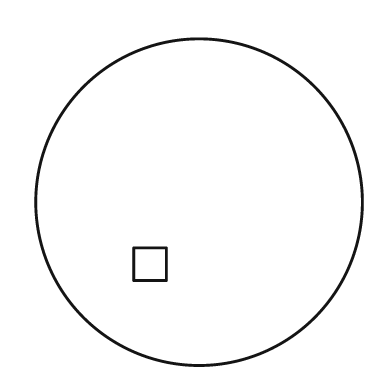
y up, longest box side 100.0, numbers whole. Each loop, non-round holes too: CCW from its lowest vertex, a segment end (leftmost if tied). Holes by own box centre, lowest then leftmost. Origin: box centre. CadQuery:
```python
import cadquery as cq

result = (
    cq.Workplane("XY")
    .moveTo(0.0, 0.0)
    .circle(50.0)
    .moveTo(-20.0, -24.0)
    .lineTo(-10.0, -24.0)
    .lineTo(-10.0, -14.0)
    .lineTo(-20.0, -14.0)
    .close()
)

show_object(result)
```